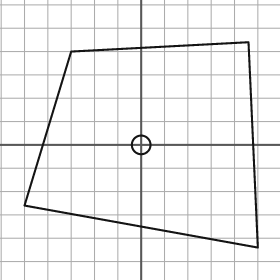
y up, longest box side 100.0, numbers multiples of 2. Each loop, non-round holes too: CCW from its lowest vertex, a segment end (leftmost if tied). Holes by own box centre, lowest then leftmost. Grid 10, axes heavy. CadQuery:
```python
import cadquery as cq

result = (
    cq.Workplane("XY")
    .moveTo(50.0, -44.0)
    .lineTo(46.0, 44.0)
    .lineTo(-30.0, 40.0)
    .lineTo(-50.0, -26.0)
    .close()
    .moveTo(0.0, 0.0)
    .circle(4.0)
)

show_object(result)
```